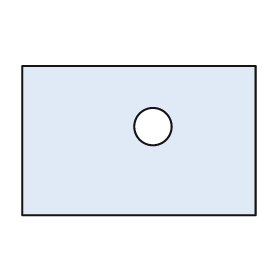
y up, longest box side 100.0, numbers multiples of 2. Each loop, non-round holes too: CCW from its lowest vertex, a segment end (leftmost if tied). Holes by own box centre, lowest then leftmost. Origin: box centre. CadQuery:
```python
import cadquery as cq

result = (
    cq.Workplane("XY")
    .moveTo(-50.0, -32.0)
    .lineTo(50.0, -32.0)
    .lineTo(50.0, 32.0)
    .lineTo(-50.0, 32.0)
    .close()
    .moveTo(6.0, 6.0)
    .circle(8.0)
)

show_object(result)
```